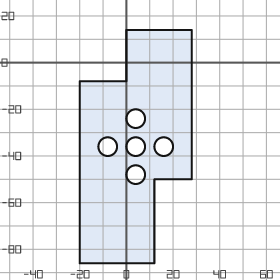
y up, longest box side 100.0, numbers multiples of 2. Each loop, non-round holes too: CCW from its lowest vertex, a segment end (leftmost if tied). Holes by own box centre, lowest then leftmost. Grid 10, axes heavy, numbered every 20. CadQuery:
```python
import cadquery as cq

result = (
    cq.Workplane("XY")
    .moveTo(-20.0, -86.0)
    .lineTo(12.0, -86.0)
    .lineTo(12.0, -50.0)
    .lineTo(28.0, -50.0)
    .lineTo(28.0, 14.0)
    .lineTo(0.0, 14.0)
    .lineTo(0.0, -8.0)
    .lineTo(-20.0, -8.0)
    .close()
    .moveTo(4.0, -48.0)
    .circle(4.0)
    .moveTo(-8.0, -36.0)
    .circle(4.0)
    .moveTo(4.0, -36.0)
    .circle(4.0)
    .moveTo(16.0, -36.0)
    .circle(4.0)
    .moveTo(4.0, -24.0)
    .circle(4.0)
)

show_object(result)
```